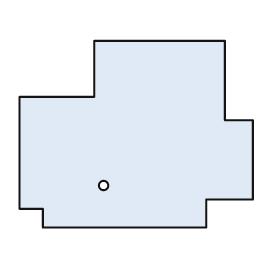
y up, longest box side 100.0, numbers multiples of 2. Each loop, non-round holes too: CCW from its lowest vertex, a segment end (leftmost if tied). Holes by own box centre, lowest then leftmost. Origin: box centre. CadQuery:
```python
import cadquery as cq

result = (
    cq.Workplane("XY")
    .moveTo(-40.0, -40.0)
    .lineTo(30.0, -40.0)
    .lineTo(30.0, -28.0)
    .lineTo(50.0, -28.0)
    .lineTo(50.0, 6.0)
    .lineTo(38.0, 6.0)
    .lineTo(38.0, 40.0)
    .lineTo(-18.0, 40.0)
    .lineTo(-18.0, 16.0)
    .lineTo(-50.0, 16.0)
    .lineTo(-50.0, -32.0)
    .lineTo(-40.0, -32.0)
    .close()
    .moveTo(-14.0, -22.0)
    .circle(2.0)
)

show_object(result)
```